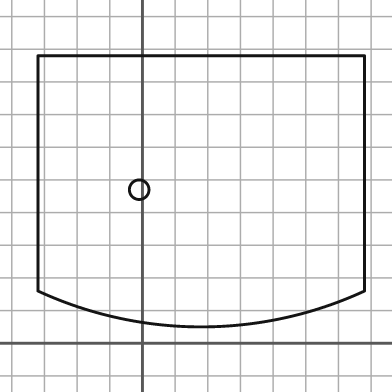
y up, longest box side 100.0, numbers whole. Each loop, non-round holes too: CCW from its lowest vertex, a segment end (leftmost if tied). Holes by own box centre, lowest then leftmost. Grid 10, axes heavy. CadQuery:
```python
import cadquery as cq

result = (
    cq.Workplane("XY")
    .moveTo(-32.0, 16.0)
    .threePointArc((18.0, 5.0), (68.0, 16.0))
    .lineTo(68.0, 88.0)
    .lineTo(-32.0, 88.0)
    .close()
    .moveTo(-1.0, 47.0)
    .circle(3.0)
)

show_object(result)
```